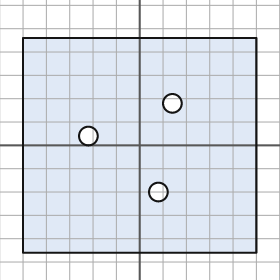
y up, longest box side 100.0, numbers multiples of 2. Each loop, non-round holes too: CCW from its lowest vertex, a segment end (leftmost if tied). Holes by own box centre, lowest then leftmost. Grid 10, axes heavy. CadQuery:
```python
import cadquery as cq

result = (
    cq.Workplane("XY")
    .moveTo(-50.0, -46.0)
    .lineTo(50.0, -46.0)
    .lineTo(50.0, 46.0)
    .lineTo(-50.0, 46.0)
    .close()
    .moveTo(8.0, -20.0)
    .circle(4.0)
    .moveTo(-22.0, 4.0)
    .circle(4.0)
    .moveTo(14.0, 18.0)
    .circle(4.0)
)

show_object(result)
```